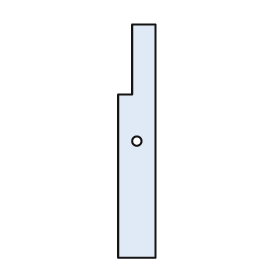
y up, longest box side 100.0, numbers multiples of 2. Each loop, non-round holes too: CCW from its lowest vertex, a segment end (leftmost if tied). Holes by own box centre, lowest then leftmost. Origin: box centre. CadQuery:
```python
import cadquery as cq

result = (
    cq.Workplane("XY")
    .moveTo(-8.0, -50.0)
    .lineTo(8.0, -50.0)
    .lineTo(8.0, 50.0)
    .lineTo(-2.0, 50.0)
    .lineTo(-2.0, 20.0)
    .lineTo(-8.0, 20.0)
    .close()
    .moveTo(0.0, 0.0)
    .circle(2.0)
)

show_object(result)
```